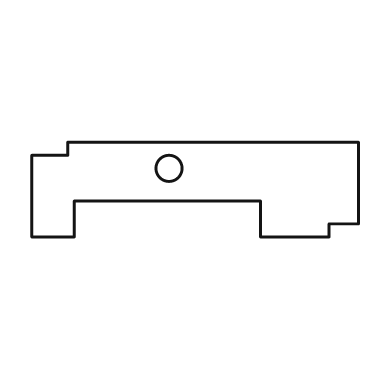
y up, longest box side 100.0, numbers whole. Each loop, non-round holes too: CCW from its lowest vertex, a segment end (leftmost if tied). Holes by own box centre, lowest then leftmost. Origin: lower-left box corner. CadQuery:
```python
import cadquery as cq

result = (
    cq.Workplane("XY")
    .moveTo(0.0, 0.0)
    .lineTo(13.0, 0.0)
    .lineTo(13.0, 11.0)
    .lineTo(70.0, 11.0)
    .lineTo(70.0, 0.0)
    .lineTo(91.0, 0.0)
    .lineTo(91.0, 4.0)
    .lineTo(100.0, 4.0)
    .lineTo(100.0, 29.0)
    .lineTo(11.0, 29.0)
    .lineTo(11.0, 25.0)
    .lineTo(0.0, 25.0)
    .close()
    .moveTo(42.0, 21.0)
    .circle(4.0)
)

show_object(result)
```